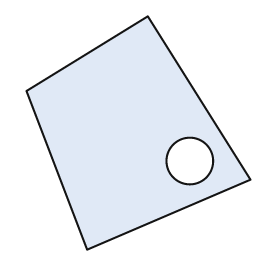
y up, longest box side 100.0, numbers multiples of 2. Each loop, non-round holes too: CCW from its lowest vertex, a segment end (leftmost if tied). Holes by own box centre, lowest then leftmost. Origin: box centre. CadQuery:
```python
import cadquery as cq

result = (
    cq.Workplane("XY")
    .moveTo(-22.0, -50.0)
    .lineTo(48.0, -20.0)
    .lineTo(4.0, 50.0)
    .lineTo(-48.0, 18.0)
    .close()
    .moveTo(22.0, -12.0)
    .circle(10.0)
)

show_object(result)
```